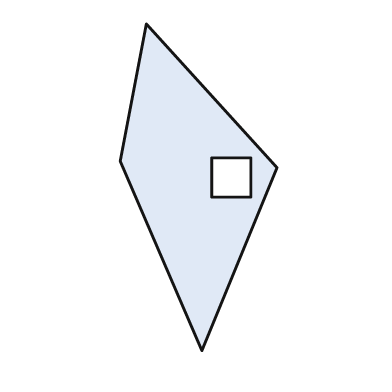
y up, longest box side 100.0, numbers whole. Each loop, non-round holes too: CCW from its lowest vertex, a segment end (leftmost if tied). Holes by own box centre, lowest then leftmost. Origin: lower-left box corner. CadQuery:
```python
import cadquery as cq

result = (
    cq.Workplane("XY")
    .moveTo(25.0, 0.0)
    .lineTo(48.0, 56.0)
    .lineTo(8.0, 100.0)
    .lineTo(0.0, 58.0)
    .close()
    .moveTo(28.0, 47.0)
    .lineTo(40.0, 47.0)
    .lineTo(40.0, 59.0)
    .lineTo(28.0, 59.0)
    .close()
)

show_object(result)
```